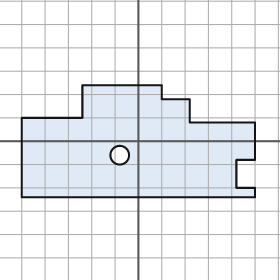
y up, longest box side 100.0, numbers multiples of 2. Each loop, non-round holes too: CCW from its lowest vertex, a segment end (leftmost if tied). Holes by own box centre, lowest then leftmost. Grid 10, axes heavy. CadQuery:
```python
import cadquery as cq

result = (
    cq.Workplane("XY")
    .moveTo(-50.0, -24.0)
    .lineTo(50.0, -24.0)
    .lineTo(50.0, -20.0)
    .lineTo(42.0, -20.0)
    .lineTo(42.0, -8.0)
    .lineTo(50.0, -8.0)
    .lineTo(50.0, 8.0)
    .lineTo(22.0, 8.0)
    .lineTo(22.0, 18.0)
    .lineTo(10.0, 18.0)
    .lineTo(10.0, 24.0)
    .lineTo(-24.0, 24.0)
    .lineTo(-24.0, 10.0)
    .lineTo(-50.0, 10.0)
    .close()
    .moveTo(-8.0, -6.0)
    .circle(4.0)
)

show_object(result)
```